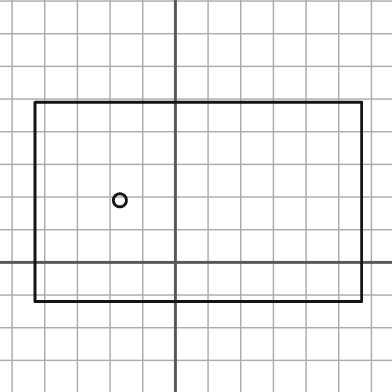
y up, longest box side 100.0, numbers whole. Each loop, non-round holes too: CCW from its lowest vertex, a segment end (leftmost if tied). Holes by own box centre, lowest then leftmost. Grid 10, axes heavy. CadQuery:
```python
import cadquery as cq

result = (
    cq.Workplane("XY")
    .moveTo(-43.0, -12.0)
    .lineTo(57.0, -12.0)
    .lineTo(57.0, 49.0)
    .lineTo(-43.0, 49.0)
    .close()
    .moveTo(-17.0, 19.0)
    .circle(2.0)
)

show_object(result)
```